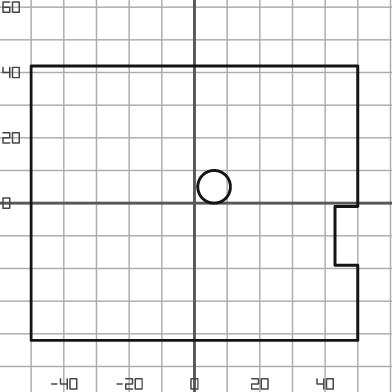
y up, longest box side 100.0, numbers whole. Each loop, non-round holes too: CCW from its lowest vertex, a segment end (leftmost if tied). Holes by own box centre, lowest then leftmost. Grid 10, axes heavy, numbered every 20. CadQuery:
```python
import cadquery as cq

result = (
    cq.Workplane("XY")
    .moveTo(-50.0, -42.0)
    .lineTo(50.0, -42.0)
    .lineTo(50.0, -19.0)
    .lineTo(43.0, -19.0)
    .lineTo(43.0, -1.0)
    .lineTo(50.0, -1.0)
    .lineTo(50.0, 42.0)
    .lineTo(-50.0, 42.0)
    .close()
    .moveTo(6.0, 5.0)
    .circle(5.0)
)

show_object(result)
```